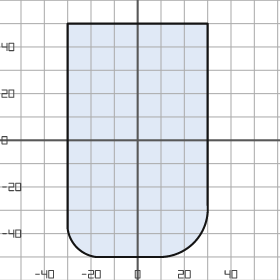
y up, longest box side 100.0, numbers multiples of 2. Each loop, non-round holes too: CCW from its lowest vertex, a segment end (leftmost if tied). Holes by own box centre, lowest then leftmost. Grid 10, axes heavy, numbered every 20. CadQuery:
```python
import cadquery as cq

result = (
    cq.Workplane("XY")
    .moveTo(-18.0, -50.0)
    .lineTo(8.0, -50.0)
    .threePointArc((24.0, -44.0), (30.0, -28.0))
    .lineTo(30.0, 50.0)
    .lineTo(-30.0, 50.0)
    .lineTo(-30.0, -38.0)
    .threePointArc((-26.0, -46.0), (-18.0, -50.0))
    .close()
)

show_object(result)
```